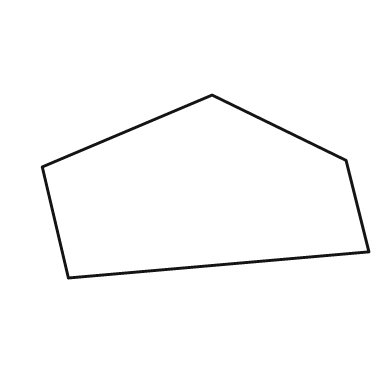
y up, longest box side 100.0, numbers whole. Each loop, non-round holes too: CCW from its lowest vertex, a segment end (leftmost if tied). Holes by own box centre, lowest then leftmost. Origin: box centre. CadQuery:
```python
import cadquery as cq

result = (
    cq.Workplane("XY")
    .moveTo(-42.0, -28.0)
    .lineTo(50.0, -20.0)
    .lineTo(43.0, 8.0)
    .lineTo(2.0, 28.0)
    .lineTo(-50.0, 6.0)
    .close()
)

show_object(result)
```